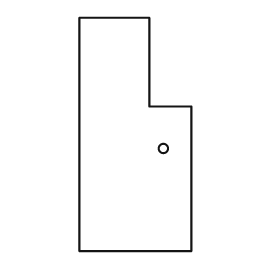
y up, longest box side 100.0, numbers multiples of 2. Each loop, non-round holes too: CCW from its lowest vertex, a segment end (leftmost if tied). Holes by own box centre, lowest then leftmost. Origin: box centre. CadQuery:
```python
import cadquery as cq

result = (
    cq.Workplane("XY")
    .moveTo(-24.0, -50.0)
    .lineTo(24.0, -50.0)
    .lineTo(24.0, 12.0)
    .lineTo(6.0, 12.0)
    .lineTo(6.0, 50.0)
    .lineTo(-24.0, 50.0)
    .close()
    .moveTo(12.0, -6.0)
    .circle(2.0)
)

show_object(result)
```